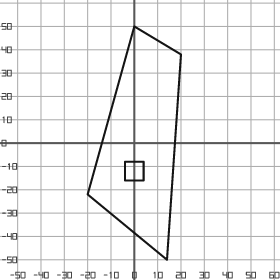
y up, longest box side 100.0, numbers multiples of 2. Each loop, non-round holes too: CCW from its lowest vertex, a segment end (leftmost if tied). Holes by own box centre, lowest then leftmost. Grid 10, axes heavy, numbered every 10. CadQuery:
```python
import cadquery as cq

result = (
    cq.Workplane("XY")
    .moveTo(14.0, -50.0)
    .lineTo(20.0, 38.0)
    .lineTo(0.0, 50.0)
    .lineTo(-20.0, -22.0)
    .close()
    .moveTo(-4.0, -16.0)
    .lineTo(4.0, -16.0)
    .lineTo(4.0, -8.0)
    .lineTo(-4.0, -8.0)
    .close()
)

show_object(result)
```